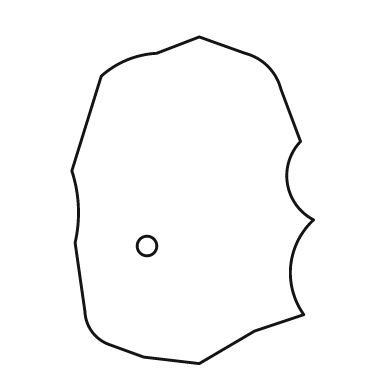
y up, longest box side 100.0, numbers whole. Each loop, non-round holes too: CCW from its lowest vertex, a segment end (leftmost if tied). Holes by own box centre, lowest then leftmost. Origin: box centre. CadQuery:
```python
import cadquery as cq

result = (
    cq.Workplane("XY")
    .moveTo(2.0, -50.0)
    .lineTo(19.0, -40.0)
    .lineTo(34.0, -35.0)
    .threePointArc((30.0, -20.0), (37.0, -6.0))
    .threePointArc((29.0, 5.0), (33.0, 18.0))
    .lineTo(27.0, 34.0)
    .threePointArc((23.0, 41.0), (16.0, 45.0))
    .lineTo(2.0, 50.0)
    .lineTo(-11.0, 45.0)
    .threePointArc((-20.0, 43.0), (-28.0, 38.0))
    .lineTo(-37.0, 9.0)
    .threePointArc((-35.0, -2.0), (-36.0, -13.0))
    .lineTo(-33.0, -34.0)
    .threePointArc((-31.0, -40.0), (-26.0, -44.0))
    .lineTo(-15.0, -48.0)
    .close()
    .moveTo(-14.0, -14.0)
    .circle(3.0)
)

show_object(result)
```